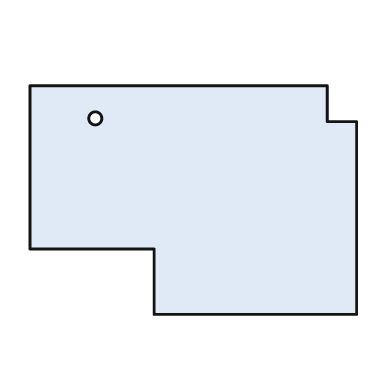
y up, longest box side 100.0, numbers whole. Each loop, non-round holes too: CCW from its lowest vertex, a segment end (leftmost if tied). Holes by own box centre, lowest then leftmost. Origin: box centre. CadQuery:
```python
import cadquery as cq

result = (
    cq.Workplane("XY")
    .moveTo(-12.0, -35.0)
    .lineTo(50.0, -35.0)
    .lineTo(50.0, 24.0)
    .lineTo(41.0, 24.0)
    .lineTo(41.0, 35.0)
    .lineTo(-50.0, 35.0)
    .lineTo(-50.0, -15.0)
    .lineTo(-12.0, -15.0)
    .close()
    .moveTo(-30.0, 25.0)
    .circle(2.0)
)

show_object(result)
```